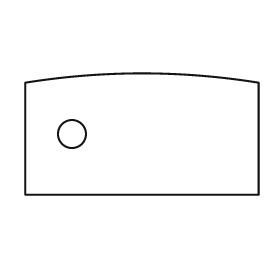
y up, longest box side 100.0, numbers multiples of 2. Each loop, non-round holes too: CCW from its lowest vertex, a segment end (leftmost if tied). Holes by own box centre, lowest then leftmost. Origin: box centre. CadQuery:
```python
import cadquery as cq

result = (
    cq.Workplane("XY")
    .moveTo(-50.0, -26.0)
    .lineTo(50.0, -26.0)
    .lineTo(50.0, 22.0)
    .threePointArc((0.0, 26.0), (-50.0, 22.0))
    .close()
    .moveTo(-30.0, 0.0)
    .circle(6.0)
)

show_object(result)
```